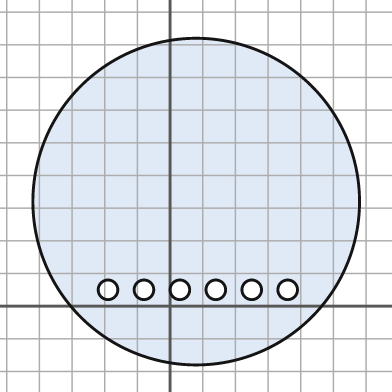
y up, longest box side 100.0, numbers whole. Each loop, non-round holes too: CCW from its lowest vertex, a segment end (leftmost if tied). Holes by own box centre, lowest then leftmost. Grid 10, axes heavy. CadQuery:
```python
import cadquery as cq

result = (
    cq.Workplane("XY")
    .moveTo(8.0, 32.0)
    .circle(50.0)
    .moveTo(-19.0, 5.0)
    .circle(3.0)
    .moveTo(-8.0, 5.0)
    .circle(3.0)
    .moveTo(3.0, 5.0)
    .circle(3.0)
    .moveTo(14.0, 5.0)
    .circle(3.0)
    .moveTo(25.0, 5.0)
    .circle(3.0)
    .moveTo(36.0, 5.0)
    .circle(3.0)
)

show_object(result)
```